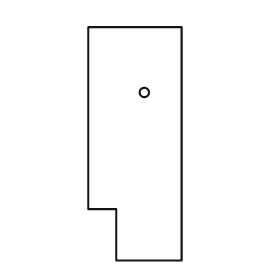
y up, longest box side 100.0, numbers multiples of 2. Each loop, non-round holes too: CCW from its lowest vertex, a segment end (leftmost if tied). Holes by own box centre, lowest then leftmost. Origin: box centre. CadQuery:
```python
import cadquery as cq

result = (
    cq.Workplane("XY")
    .moveTo(-8.0, -50.0)
    .lineTo(20.0, -50.0)
    .lineTo(20.0, 50.0)
    .lineTo(-20.0, 50.0)
    .lineTo(-20.0, -28.0)
    .lineTo(-8.0, -28.0)
    .close()
    .moveTo(4.0, 22.0)
    .circle(2.0)
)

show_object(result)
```